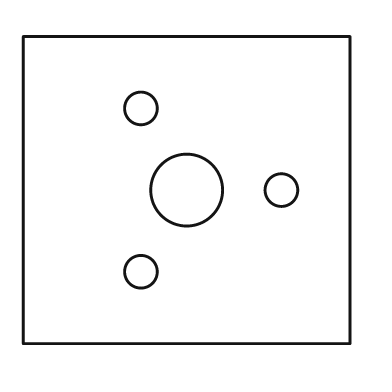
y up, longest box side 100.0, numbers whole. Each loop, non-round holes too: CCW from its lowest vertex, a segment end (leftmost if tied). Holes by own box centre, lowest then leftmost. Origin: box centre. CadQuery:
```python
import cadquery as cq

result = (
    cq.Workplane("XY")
    .moveTo(-50.0, -47.0)
    .lineTo(50.0, -47.0)
    .lineTo(50.0, 47.0)
    .lineTo(-50.0, 47.0)
    .close()
    .moveTo(-14.0, -25.0)
    .circle(5.0)
    .moveTo(0.0, 0.0)
    .circle(11.0)
    .moveTo(29.0, 0.0)
    .circle(5.0)
    .moveTo(-14.0, 25.0)
    .circle(5.0)
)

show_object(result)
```